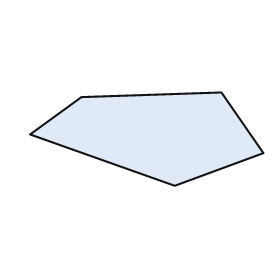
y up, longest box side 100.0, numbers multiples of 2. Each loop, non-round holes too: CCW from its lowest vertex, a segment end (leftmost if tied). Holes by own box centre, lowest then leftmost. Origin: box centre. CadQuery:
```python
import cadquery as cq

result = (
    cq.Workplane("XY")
    .moveTo(12.0, -20.0)
    .lineTo(50.0, -6.0)
    .lineTo(32.0, 20.0)
    .lineTo(-28.0, 18.0)
    .lineTo(-50.0, 2.0)
    .close()
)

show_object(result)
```